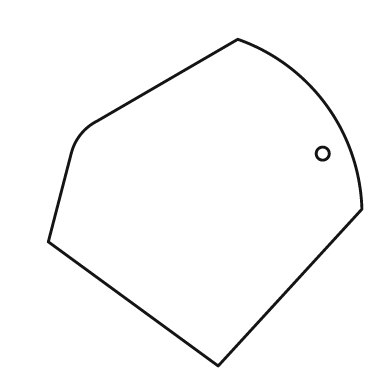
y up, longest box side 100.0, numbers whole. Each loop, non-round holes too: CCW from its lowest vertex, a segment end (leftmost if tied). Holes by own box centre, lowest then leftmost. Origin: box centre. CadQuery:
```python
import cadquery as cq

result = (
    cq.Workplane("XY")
    .moveTo(4.0, -50.0)
    .lineTo(48.0, -2.0)
    .threePointArc((37.0, 30.0), (10.0, 50.0))
    .lineTo(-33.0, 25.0)
    .threePointArc((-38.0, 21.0), (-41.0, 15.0))
    .lineTo(-48.0, -12.0)
    .close()
    .moveTo(36.0, 15.0)
    .circle(2.0)
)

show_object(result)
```